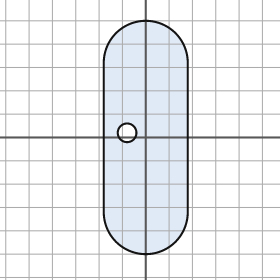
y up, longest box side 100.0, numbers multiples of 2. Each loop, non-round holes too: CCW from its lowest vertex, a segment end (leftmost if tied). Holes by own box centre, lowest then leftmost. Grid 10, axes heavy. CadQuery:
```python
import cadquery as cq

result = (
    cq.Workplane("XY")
    .moveTo(-18.0, -32.0)
    .threePointArc((0.0, -50.0), (18.0, -32.0))
    .lineTo(18.0, 32.0)
    .threePointArc((0.0, 50.0), (-18.0, 32.0))
    .close()
    .moveTo(-8.0, 2.0)
    .circle(4.0)
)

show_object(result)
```